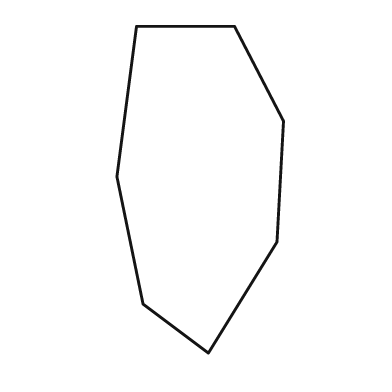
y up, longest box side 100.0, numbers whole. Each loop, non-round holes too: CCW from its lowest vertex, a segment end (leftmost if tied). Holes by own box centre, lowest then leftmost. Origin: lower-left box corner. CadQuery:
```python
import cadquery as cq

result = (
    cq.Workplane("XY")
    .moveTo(28.0, 0.0)
    .lineTo(49.0, 34.0)
    .lineTo(51.0, 71.0)
    .lineTo(36.0, 100.0)
    .lineTo(6.0, 100.0)
    .lineTo(0.0, 54.0)
    .lineTo(8.0, 15.0)
    .close()
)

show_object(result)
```